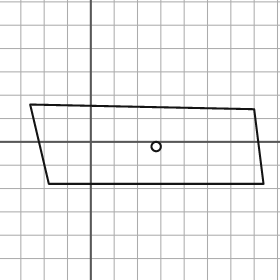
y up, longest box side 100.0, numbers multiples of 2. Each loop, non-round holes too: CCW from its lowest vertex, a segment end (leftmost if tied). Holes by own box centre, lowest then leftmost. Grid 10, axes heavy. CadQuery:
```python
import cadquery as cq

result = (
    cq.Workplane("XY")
    .moveTo(-18.0, -18.0)
    .lineTo(74.0, -18.0)
    .lineTo(70.0, 14.0)
    .lineTo(-26.0, 16.0)
    .close()
    .moveTo(28.0, -2.0)
    .circle(2.0)
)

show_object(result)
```